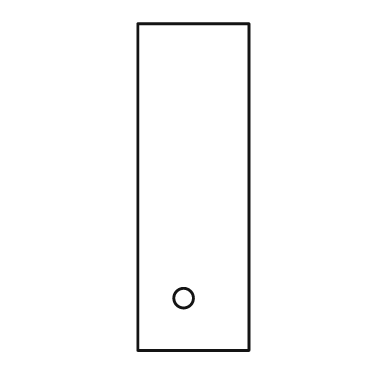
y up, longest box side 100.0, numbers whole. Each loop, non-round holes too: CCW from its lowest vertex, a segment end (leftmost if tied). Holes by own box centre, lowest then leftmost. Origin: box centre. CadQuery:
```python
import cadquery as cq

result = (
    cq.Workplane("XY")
    .moveTo(-17.0, -50.0)
    .lineTo(17.0, -50.0)
    .lineTo(17.0, 50.0)
    .lineTo(-17.0, 50.0)
    .close()
    .moveTo(-3.0, -34.0)
    .circle(3.0)
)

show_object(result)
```